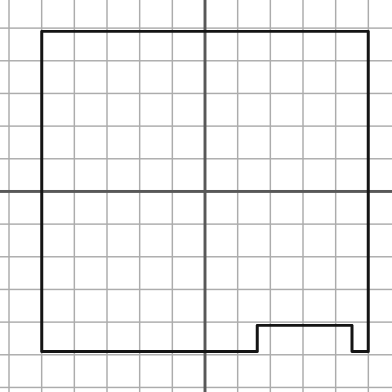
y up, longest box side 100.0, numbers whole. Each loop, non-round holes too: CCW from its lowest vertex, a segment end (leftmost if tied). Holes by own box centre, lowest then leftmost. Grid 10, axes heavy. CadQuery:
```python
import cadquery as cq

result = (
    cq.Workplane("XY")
    .moveTo(-50.0, -49.0)
    .lineTo(16.0, -49.0)
    .lineTo(16.0, -41.0)
    .lineTo(45.0, -41.0)
    .lineTo(45.0, -49.0)
    .lineTo(50.0, -49.0)
    .lineTo(50.0, 49.0)
    .lineTo(-50.0, 49.0)
    .close()
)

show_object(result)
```